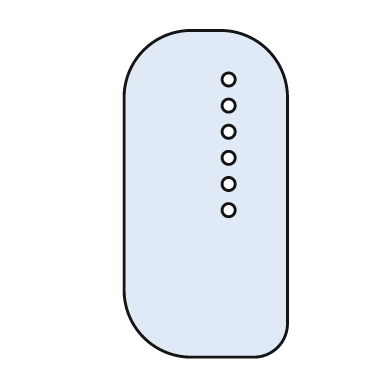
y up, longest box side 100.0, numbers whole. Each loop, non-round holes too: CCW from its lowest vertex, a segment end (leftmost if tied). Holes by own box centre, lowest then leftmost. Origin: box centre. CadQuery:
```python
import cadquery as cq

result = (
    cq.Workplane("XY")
    .moveTo(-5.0, -50.0)
    .lineTo(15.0, -50.0)
    .threePointArc((22.0, -47.0), (25.0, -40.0))
    .lineTo(25.0, 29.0)
    .threePointArc((19.0, 44.0), (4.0, 50.0))
    .lineTo(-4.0, 50.0)
    .threePointArc((-19.0, 44.0), (-25.0, 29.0))
    .lineTo(-25.0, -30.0)
    .threePointArc((-19.0, -44.0), (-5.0, -50.0))
    .close()
    .moveTo(7.0, -5.0)
    .circle(2.0)
    .moveTo(7.0, 3.0)
    .circle(2.0)
    .moveTo(7.0, 11.0)
    .circle(2.0)
    .moveTo(7.0, 19.0)
    .circle(2.0)
    .moveTo(7.0, 27.0)
    .circle(2.0)
    .moveTo(7.0, 35.0)
    .circle(2.0)
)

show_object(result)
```